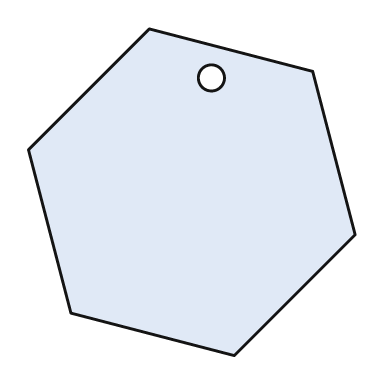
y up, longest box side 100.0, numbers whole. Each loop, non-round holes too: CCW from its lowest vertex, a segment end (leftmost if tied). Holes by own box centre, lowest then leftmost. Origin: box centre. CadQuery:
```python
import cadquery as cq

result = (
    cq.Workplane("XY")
    .moveTo(13.0, -50.0)
    .lineTo(50.0, -13.0)
    .lineTo(37.0, 37.0)
    .lineTo(-13.0, 50.0)
    .lineTo(-50.0, 13.0)
    .lineTo(-37.0, -37.0)
    .close()
    .moveTo(6.0, 35.0)
    .circle(4.0)
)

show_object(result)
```